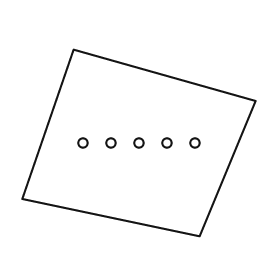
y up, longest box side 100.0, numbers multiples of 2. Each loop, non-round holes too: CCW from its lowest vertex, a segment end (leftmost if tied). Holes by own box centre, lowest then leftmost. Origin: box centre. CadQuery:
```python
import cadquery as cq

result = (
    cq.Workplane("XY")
    .moveTo(26.0, -40.0)
    .lineTo(50.0, 18.0)
    .lineTo(-28.0, 40.0)
    .lineTo(-50.0, -24.0)
    .close()
    .moveTo(-24.0, 0.0)
    .circle(2.0)
    .moveTo(-12.0, 0.0)
    .circle(2.0)
    .moveTo(0.0, 0.0)
    .circle(2.0)
    .moveTo(12.0, 0.0)
    .circle(2.0)
    .moveTo(24.0, 0.0)
    .circle(2.0)
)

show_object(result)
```